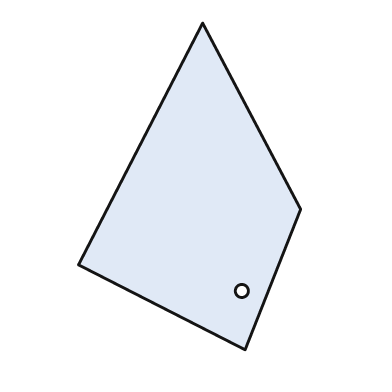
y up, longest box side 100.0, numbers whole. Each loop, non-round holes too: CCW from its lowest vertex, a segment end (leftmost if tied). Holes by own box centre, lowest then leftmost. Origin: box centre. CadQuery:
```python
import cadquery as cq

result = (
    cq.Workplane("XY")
    .moveTo(17.0, -50.0)
    .lineTo(34.0, -7.0)
    .lineTo(4.0, 50.0)
    .lineTo(-34.0, -24.0)
    .close()
    .moveTo(16.0, -32.0)
    .circle(2.0)
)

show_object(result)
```